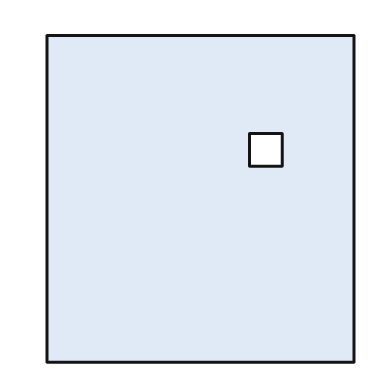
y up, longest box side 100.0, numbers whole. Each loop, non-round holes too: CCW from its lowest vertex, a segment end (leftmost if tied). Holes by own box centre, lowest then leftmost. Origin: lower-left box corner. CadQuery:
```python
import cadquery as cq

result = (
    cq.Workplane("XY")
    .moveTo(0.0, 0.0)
    .lineTo(94.0, 0.0)
    .lineTo(94.0, 100.0)
    .lineTo(0.0, 100.0)
    .close()
    .moveTo(62.0, 60.0)
    .lineTo(72.0, 60.0)
    .lineTo(72.0, 70.0)
    .lineTo(62.0, 70.0)
    .close()
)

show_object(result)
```